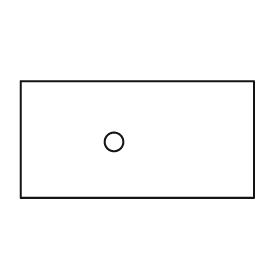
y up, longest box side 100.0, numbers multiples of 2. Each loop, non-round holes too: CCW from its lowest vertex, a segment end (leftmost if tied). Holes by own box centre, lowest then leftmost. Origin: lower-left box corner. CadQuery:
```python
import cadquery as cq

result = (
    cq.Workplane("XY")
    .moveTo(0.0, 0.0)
    .lineTo(100.0, 0.0)
    .lineTo(100.0, 50.0)
    .lineTo(0.0, 50.0)
    .close()
    .moveTo(40.0, 24.0)
    .circle(4.0)
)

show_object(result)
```